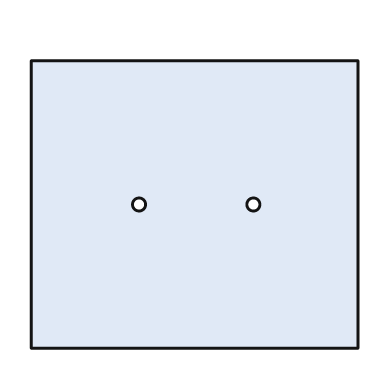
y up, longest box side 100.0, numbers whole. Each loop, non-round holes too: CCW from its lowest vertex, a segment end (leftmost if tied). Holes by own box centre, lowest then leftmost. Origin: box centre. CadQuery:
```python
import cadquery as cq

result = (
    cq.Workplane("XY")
    .moveTo(-50.0, -44.0)
    .lineTo(50.0, -44.0)
    .lineTo(50.0, 44.0)
    .lineTo(-50.0, 44.0)
    .close()
    .moveTo(-17.0, 0.0)
    .circle(2.0)
    .moveTo(18.0, 0.0)
    .circle(2.0)
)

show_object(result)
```